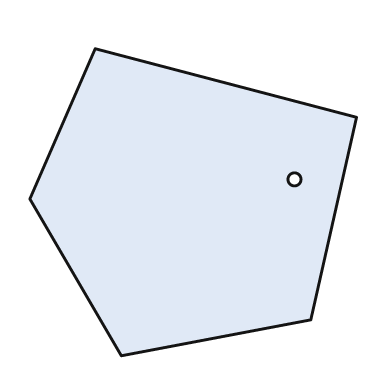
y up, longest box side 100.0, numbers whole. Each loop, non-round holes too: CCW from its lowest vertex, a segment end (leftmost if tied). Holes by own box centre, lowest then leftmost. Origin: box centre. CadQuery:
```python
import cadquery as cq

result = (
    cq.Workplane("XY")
    .moveTo(-22.0, -47.0)
    .lineTo(36.0, -36.0)
    .lineTo(50.0, 26.0)
    .lineTo(-30.0, 47.0)
    .lineTo(-50.0, 1.0)
    .close()
    .moveTo(31.0, 7.0)
    .circle(2.0)
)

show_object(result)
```